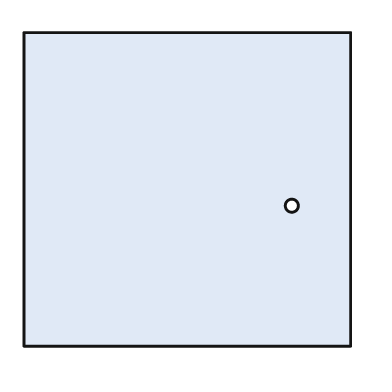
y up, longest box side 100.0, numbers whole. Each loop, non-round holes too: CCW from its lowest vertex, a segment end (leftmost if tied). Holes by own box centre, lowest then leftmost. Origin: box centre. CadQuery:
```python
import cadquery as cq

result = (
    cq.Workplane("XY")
    .moveTo(-50.0, -48.0)
    .lineTo(50.0, -48.0)
    .lineTo(50.0, 48.0)
    .lineTo(-50.0, 48.0)
    .close()
    .moveTo(32.0, -5.0)
    .circle(2.0)
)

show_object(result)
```